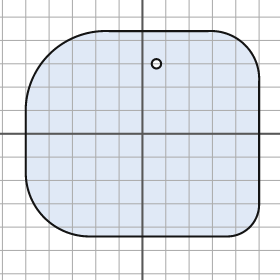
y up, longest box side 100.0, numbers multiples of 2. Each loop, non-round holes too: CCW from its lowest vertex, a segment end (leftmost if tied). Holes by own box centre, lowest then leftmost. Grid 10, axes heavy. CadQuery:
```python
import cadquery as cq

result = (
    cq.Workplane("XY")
    .moveTo(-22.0, -44.0)
    .lineTo(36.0, -44.0)
    .threePointArc((46.0, -40.0), (50.0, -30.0))
    .lineTo(50.0, 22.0)
    .threePointArc((44.0, 38.0), (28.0, 44.0))
    .lineTo(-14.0, 44.0)
    .threePointArc((-40.0, 34.0), (-50.0, 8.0))
    .lineTo(-50.0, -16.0)
    .threePointArc((-42.0, -36.0), (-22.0, -44.0))
    .close()
    .moveTo(6.0, 30.0)
    .circle(2.0)
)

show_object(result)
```